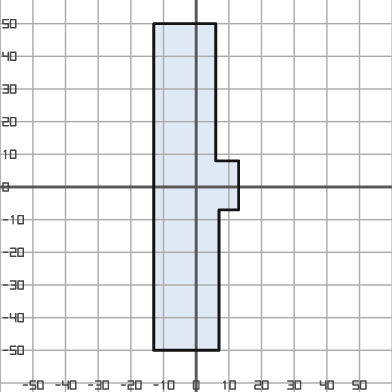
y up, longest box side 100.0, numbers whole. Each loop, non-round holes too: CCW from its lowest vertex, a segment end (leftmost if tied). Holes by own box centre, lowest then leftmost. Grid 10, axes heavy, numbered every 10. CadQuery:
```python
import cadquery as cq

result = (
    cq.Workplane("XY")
    .moveTo(-13.0, -50.0)
    .lineTo(7.0, -50.0)
    .lineTo(7.0, -7.0)
    .lineTo(13.0, -7.0)
    .lineTo(13.0, 8.0)
    .lineTo(6.0, 8.0)
    .lineTo(6.0, 50.0)
    .lineTo(-13.0, 50.0)
    .close()
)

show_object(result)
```